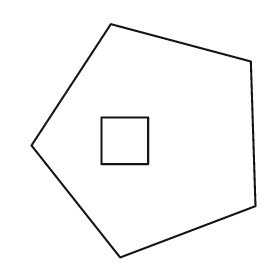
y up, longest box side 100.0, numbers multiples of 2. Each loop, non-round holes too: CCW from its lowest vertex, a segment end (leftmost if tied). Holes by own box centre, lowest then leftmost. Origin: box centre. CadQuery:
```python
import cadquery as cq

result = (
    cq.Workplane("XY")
    .moveTo(-10.0, -50.0)
    .lineTo(48.0, -28.0)
    .lineTo(46.0, 34.0)
    .lineTo(-14.0, 50.0)
    .lineTo(-48.0, -2.0)
    .close()
    .moveTo(-18.0, -10.0)
    .lineTo(2.0, -10.0)
    .lineTo(2.0, 10.0)
    .lineTo(-18.0, 10.0)
    .close()
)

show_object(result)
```